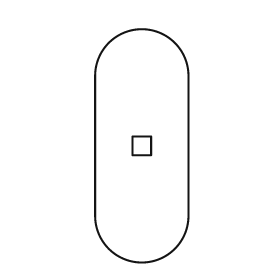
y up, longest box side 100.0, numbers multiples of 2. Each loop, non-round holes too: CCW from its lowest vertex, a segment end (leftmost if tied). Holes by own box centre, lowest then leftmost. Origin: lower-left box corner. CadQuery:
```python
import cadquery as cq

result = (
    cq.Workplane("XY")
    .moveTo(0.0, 20.0)
    .threePointArc((20.0, 0.0), (40.0, 20.0))
    .lineTo(40.0, 80.0)
    .threePointArc((20.0, 100.0), (0.0, 80.0))
    .close()
    .moveTo(16.0, 46.0)
    .lineTo(24.0, 46.0)
    .lineTo(24.0, 54.0)
    .lineTo(16.0, 54.0)
    .close()
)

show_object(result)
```